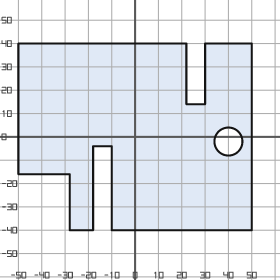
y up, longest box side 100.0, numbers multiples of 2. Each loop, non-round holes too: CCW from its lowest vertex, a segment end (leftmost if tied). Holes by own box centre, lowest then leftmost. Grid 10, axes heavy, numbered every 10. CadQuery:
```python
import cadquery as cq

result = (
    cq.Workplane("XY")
    .moveTo(-28.0, -40.0)
    .lineTo(-18.0, -40.0)
    .lineTo(-18.0, -4.0)
    .lineTo(-10.0, -4.0)
    .lineTo(-10.0, -40.0)
    .lineTo(50.0, -40.0)
    .lineTo(50.0, 40.0)
    .lineTo(30.0, 40.0)
    .lineTo(30.0, 14.0)
    .lineTo(22.0, 14.0)
    .lineTo(22.0, 40.0)
    .lineTo(-50.0, 40.0)
    .lineTo(-50.0, -16.0)
    .lineTo(-28.0, -16.0)
    .close()
    .moveTo(40.0, -2.0)
    .circle(6.0)
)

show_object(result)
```